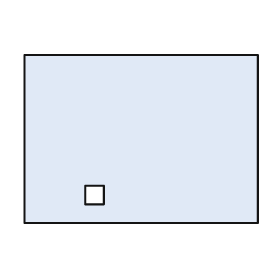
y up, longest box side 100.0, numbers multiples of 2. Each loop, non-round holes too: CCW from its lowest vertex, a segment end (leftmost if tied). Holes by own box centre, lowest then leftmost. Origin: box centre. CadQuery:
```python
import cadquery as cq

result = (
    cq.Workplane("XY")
    .moveTo(-50.0, -36.0)
    .lineTo(50.0, -36.0)
    .lineTo(50.0, 36.0)
    .lineTo(-50.0, 36.0)
    .close()
    .moveTo(-24.0, -28.0)
    .lineTo(-16.0, -28.0)
    .lineTo(-16.0, -20.0)
    .lineTo(-24.0, -20.0)
    .close()
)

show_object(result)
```